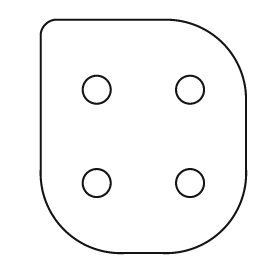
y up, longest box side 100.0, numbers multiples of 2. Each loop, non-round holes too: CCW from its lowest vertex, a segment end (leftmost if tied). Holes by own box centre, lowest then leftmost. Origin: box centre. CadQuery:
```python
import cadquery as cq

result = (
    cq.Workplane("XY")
    .moveTo(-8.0, -50.0)
    .lineTo(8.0, -50.0)
    .threePointArc((34.0, -40.0), (44.0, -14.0))
    .lineTo(44.0, 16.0)
    .threePointArc((34.0, 40.0), (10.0, 50.0))
    .lineTo(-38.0, 50.0)
    .threePointArc((-42.0, 48.0), (-44.0, 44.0))
    .lineTo(-44.0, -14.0)
    .threePointArc((-34.0, -40.0), (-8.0, -50.0))
    .close()
    .moveTo(-20.0, -20.0)
    .circle(6.0)
    .moveTo(20.0, -20.0)
    .circle(6.0)
    .moveTo(-20.0, 20.0)
    .circle(6.0)
    .moveTo(20.0, 20.0)
    .circle(6.0)
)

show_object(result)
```